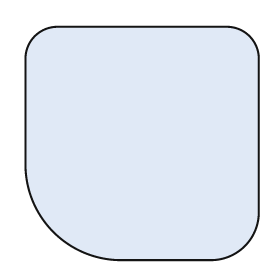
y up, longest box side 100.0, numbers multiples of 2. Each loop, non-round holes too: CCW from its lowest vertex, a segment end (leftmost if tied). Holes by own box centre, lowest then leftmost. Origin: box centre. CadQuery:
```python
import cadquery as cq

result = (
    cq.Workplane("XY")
    .moveTo(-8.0, -50.0)
    .lineTo(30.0, -50.0)
    .threePointArc((44.0, -44.0), (50.0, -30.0))
    .lineTo(50.0, 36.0)
    .threePointArc((46.0, 46.0), (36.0, 50.0))
    .lineTo(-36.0, 50.0)
    .threePointArc((-46.0, 46.0), (-50.0, 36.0))
    .lineTo(-50.0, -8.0)
    .threePointArc((-38.0, -38.0), (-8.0, -50.0))
    .close()
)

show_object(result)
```